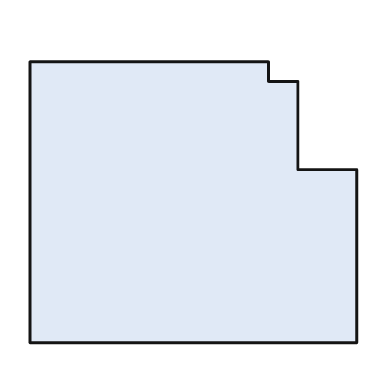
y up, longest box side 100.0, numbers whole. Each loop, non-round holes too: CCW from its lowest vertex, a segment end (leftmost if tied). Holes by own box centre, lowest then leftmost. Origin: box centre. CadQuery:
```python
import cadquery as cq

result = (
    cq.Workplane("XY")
    .moveTo(-50.0, -43.0)
    .lineTo(50.0, -43.0)
    .lineTo(50.0, 10.0)
    .lineTo(32.0, 10.0)
    .lineTo(32.0, 37.0)
    .lineTo(23.0, 37.0)
    .lineTo(23.0, 43.0)
    .lineTo(-50.0, 43.0)
    .close()
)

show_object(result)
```